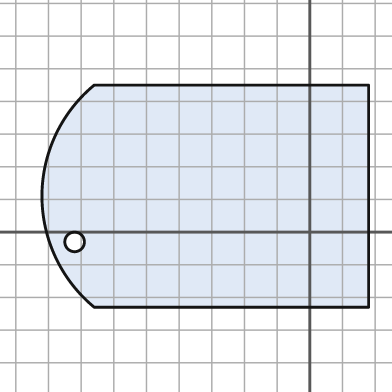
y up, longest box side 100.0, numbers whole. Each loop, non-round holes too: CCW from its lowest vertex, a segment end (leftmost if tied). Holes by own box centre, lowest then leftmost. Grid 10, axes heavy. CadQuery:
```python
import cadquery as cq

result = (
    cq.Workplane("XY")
    .moveTo(-66.0, -23.0)
    .lineTo(18.0, -23.0)
    .lineTo(18.0, 45.0)
    .lineTo(-66.0, 45.0)
    .threePointArc((-82.0, 11.0), (-66.0, -23.0))
    .close()
    .moveTo(-72.0, -3.0)
    .circle(3.0)
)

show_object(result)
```